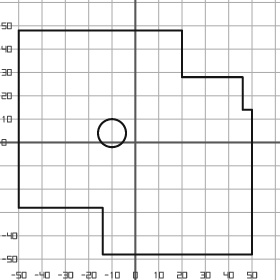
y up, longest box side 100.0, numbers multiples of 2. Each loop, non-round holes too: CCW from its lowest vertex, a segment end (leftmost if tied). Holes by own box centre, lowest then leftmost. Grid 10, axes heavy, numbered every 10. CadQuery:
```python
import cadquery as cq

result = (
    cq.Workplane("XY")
    .moveTo(-14.0, -48.0)
    .lineTo(50.0, -48.0)
    .lineTo(50.0, 14.0)
    .lineTo(46.0, 14.0)
    .lineTo(46.0, 28.0)
    .lineTo(20.0, 28.0)
    .lineTo(20.0, 48.0)
    .lineTo(-50.0, 48.0)
    .lineTo(-50.0, -28.0)
    .lineTo(-14.0, -28.0)
    .close()
    .moveTo(-10.0, 4.0)
    .circle(6.0)
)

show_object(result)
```